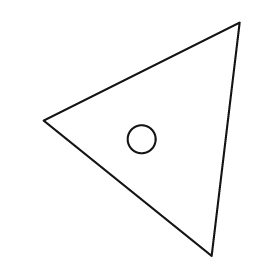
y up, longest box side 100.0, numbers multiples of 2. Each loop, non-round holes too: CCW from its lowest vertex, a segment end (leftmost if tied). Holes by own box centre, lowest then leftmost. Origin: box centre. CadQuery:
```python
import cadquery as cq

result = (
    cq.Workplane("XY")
    .moveTo(30.0, -50.0)
    .lineTo(42.0, 50.0)
    .lineTo(-42.0, 8.0)
    .close()
    .moveTo(0.0, 0.0)
    .circle(6.0)
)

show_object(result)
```